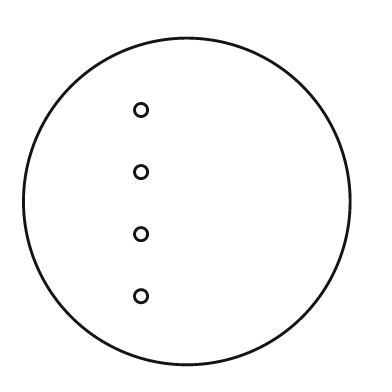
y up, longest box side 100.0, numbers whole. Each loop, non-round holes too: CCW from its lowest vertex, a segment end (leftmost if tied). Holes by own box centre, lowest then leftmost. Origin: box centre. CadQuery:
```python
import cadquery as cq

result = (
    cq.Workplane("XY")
    .moveTo(0.0, 0.0)
    .circle(50.0)
    .moveTo(-14.0, -29.0)
    .circle(2.0)
    .moveTo(-14.0, -10.0)
    .circle(2.0)
    .moveTo(-14.0, 9.0)
    .circle(2.0)
    .moveTo(-14.0, 28.0)
    .circle(2.0)
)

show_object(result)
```